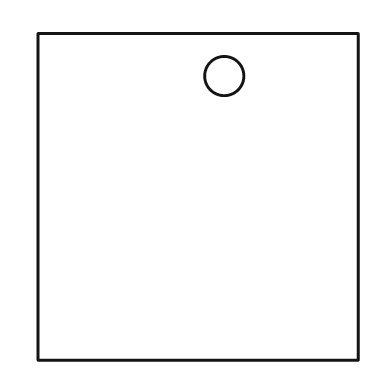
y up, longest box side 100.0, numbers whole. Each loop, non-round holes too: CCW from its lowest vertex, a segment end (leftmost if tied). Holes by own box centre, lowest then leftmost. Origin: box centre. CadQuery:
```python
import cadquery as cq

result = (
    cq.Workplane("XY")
    .moveTo(-49.0, -50.0)
    .lineTo(49.0, -50.0)
    .lineTo(49.0, 50.0)
    .lineTo(-49.0, 50.0)
    .close()
    .moveTo(8.0, 37.0)
    .circle(6.0)
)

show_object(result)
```